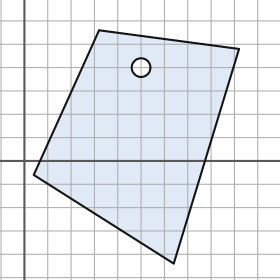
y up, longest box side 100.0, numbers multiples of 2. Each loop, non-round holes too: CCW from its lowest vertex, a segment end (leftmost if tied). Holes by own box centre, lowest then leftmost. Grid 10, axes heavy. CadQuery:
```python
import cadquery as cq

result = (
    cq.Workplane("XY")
    .moveTo(64.0, -44.0)
    .lineTo(92.0, 48.0)
    .lineTo(32.0, 56.0)
    .lineTo(4.0, -6.0)
    .close()
    .moveTo(50.0, 40.0)
    .circle(4.0)
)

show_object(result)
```